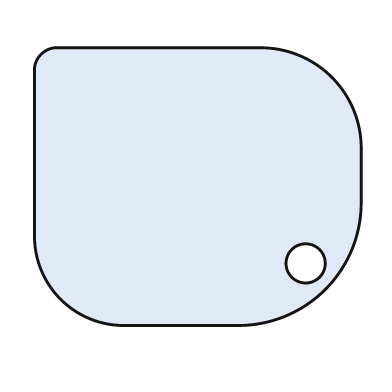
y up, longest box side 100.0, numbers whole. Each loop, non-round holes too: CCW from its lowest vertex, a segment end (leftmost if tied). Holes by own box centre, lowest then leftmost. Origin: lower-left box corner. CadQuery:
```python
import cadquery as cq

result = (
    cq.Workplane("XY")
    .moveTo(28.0, 0.0)
    .lineTo(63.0, 0.0)
    .threePointArc((89.0, 11.0), (100.0, 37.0))
    .lineTo(100.0, 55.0)
    .threePointArc((91.0, 76.0), (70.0, 85.0))
    .lineTo(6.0, 85.0)
    .threePointArc((2.0, 83.0), (0.0, 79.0))
    .lineTo(0.0, 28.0)
    .threePointArc((8.0, 8.0), (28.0, 0.0))
    .close()
    .moveTo(83.0, 19.0)
    .circle(6.0)
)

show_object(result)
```